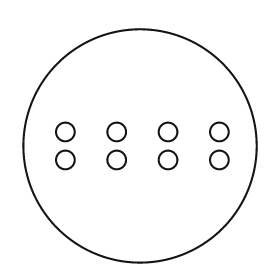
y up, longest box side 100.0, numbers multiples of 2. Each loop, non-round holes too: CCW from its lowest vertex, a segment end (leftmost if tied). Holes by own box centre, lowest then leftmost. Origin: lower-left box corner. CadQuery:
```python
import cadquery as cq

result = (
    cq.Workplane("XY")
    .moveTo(50.0, 50.0)
    .circle(50.0)
    .moveTo(18.0, 44.0)
    .circle(4.0)
    .moveTo(40.0, 44.0)
    .circle(4.0)
    .moveTo(62.0, 44.0)
    .circle(4.0)
    .moveTo(84.0, 44.0)
    .circle(4.0)
    .moveTo(18.0, 56.0)
    .circle(4.0)
    .moveTo(40.0, 56.0)
    .circle(4.0)
    .moveTo(62.0, 56.0)
    .circle(4.0)
    .moveTo(84.0, 56.0)
    .circle(4.0)
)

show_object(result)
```